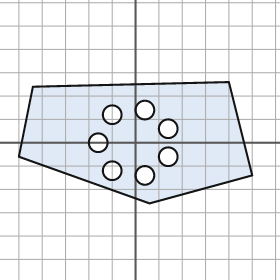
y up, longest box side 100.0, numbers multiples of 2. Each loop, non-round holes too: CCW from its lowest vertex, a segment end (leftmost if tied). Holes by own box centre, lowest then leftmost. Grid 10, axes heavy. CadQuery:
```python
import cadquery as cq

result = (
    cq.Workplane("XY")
    .moveTo(6.0, -26.0)
    .lineTo(50.0, -14.0)
    .lineTo(40.0, 26.0)
    .lineTo(-44.0, 24.0)
    .lineTo(-50.0, -6.0)
    .close()
    .moveTo(4.0, -14.0)
    .circle(4.0)
    .moveTo(-10.0, -12.0)
    .circle(4.0)
    .moveTo(14.0, -6.0)
    .circle(4.0)
    .moveTo(-16.0, 0.0)
    .circle(4.0)
    .moveTo(14.0, 6.0)
    .circle(4.0)
    .moveTo(-10.0, 12.0)
    .circle(4.0)
    .moveTo(4.0, 14.0)
    .circle(4.0)
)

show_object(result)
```